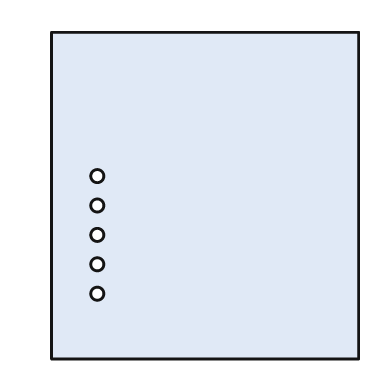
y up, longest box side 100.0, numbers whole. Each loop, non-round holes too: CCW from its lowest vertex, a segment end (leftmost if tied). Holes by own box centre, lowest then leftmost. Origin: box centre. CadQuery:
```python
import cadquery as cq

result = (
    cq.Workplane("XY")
    .moveTo(-47.0, -50.0)
    .lineTo(47.0, -50.0)
    .lineTo(47.0, 50.0)
    .lineTo(-47.0, 50.0)
    .close()
    .moveTo(-33.0, -30.0)
    .circle(2.0)
    .moveTo(-33.0, -21.0)
    .circle(2.0)
    .moveTo(-33.0, -12.0)
    .circle(2.0)
    .moveTo(-33.0, -3.0)
    .circle(2.0)
    .moveTo(-33.0, 6.0)
    .circle(2.0)
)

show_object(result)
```